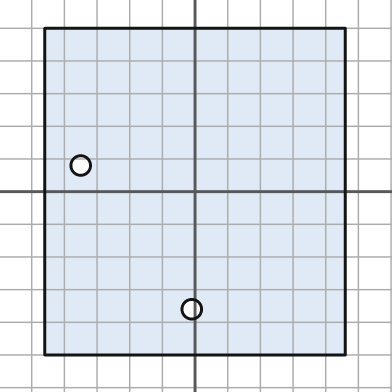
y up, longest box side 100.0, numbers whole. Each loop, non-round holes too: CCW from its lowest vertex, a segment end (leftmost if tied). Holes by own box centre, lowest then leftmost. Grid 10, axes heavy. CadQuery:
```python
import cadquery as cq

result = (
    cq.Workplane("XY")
    .moveTo(-46.0, -50.0)
    .lineTo(46.0, -50.0)
    .lineTo(46.0, 50.0)
    .lineTo(-46.0, 50.0)
    .close()
    .moveTo(-1.0, -36.0)
    .circle(3.0)
    .moveTo(-35.0, 8.0)
    .circle(3.0)
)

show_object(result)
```